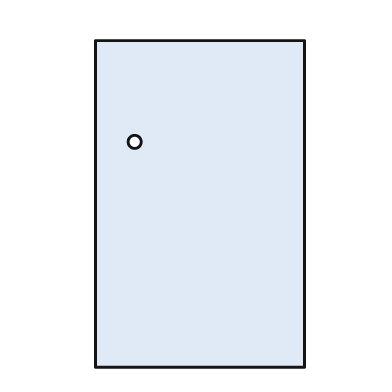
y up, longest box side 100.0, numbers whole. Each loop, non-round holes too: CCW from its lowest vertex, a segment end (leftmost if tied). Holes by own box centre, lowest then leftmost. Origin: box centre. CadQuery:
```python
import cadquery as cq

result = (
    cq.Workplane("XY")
    .moveTo(-32.0, -50.0)
    .lineTo(32.0, -50.0)
    .lineTo(32.0, 50.0)
    .lineTo(-32.0, 50.0)
    .close()
    .moveTo(-20.0, 19.0)
    .circle(2.0)
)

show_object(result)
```